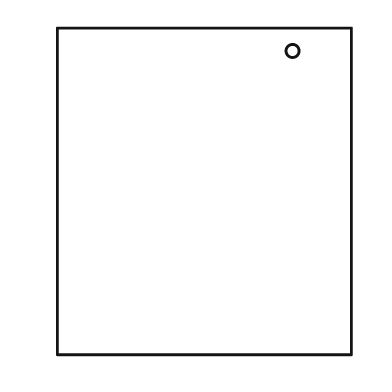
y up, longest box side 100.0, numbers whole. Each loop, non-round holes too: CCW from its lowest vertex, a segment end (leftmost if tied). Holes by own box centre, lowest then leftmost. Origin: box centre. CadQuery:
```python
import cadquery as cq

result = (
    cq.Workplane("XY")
    .moveTo(-45.0, -50.0)
    .lineTo(45.0, -50.0)
    .lineTo(45.0, 50.0)
    .lineTo(-45.0, 50.0)
    .close()
    .moveTo(27.0, 43.0)
    .circle(2.0)
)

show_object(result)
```